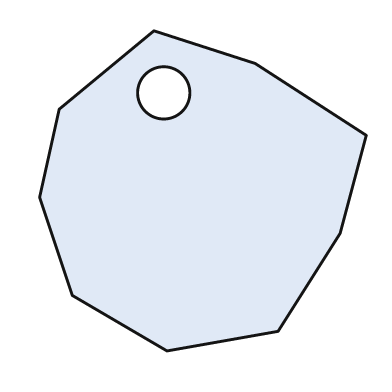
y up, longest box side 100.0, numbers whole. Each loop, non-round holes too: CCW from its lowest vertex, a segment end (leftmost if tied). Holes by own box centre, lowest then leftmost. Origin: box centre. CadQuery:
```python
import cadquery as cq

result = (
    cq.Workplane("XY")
    .moveTo(-11.0, -49.0)
    .lineTo(23.0, -43.0)
    .lineTo(42.0, -13.0)
    .lineTo(50.0, 17.0)
    .lineTo(16.0, 39.0)
    .lineTo(-15.0, 49.0)
    .lineTo(-44.0, 25.0)
    .lineTo(-50.0, -2.0)
    .lineTo(-40.0, -32.0)
    .close()
    .moveTo(-12.0, 30.0)
    .circle(8.0)
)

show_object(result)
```